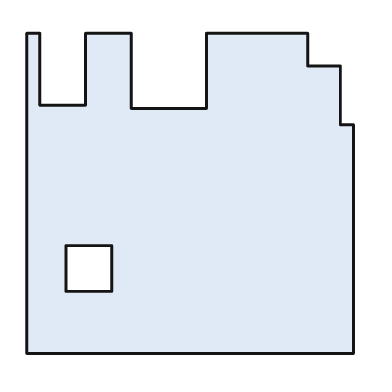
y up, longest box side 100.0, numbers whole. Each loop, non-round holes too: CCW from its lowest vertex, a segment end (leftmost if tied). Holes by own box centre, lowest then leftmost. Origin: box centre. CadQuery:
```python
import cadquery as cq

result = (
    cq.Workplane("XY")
    .moveTo(-50.0, -49.0)
    .lineTo(50.0, -49.0)
    .lineTo(50.0, 21.0)
    .lineTo(46.0, 21.0)
    .lineTo(46.0, 39.0)
    .lineTo(36.0, 39.0)
    .lineTo(36.0, 49.0)
    .lineTo(5.0, 49.0)
    .lineTo(5.0, 26.0)
    .lineTo(-18.0, 26.0)
    .lineTo(-18.0, 49.0)
    .lineTo(-32.0, 49.0)
    .lineTo(-32.0, 27.0)
    .lineTo(-46.0, 27.0)
    .lineTo(-46.0, 49.0)
    .lineTo(-50.0, 49.0)
    .close()
    .moveTo(-38.0, -30.0)
    .lineTo(-24.0, -30.0)
    .lineTo(-24.0, -16.0)
    .lineTo(-38.0, -16.0)
    .close()
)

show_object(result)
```